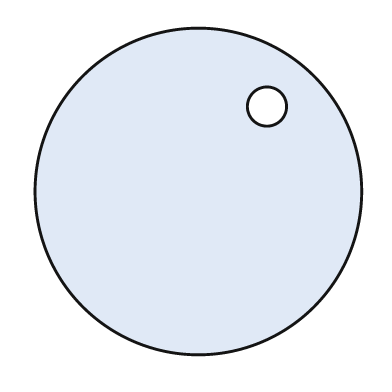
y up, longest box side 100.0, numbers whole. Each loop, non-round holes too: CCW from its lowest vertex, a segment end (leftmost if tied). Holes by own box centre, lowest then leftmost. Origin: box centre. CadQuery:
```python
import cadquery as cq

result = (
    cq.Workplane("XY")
    .moveTo(0.0, 0.0)
    .circle(50.0)
    .moveTo(21.0, 26.0)
    .circle(6.0)
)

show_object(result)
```